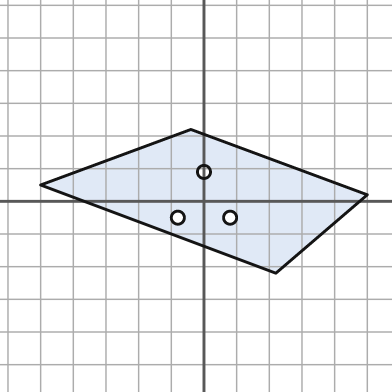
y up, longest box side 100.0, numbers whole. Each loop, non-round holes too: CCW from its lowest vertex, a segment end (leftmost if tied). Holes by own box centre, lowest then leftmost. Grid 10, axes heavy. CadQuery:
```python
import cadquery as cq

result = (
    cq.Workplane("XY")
    .moveTo(22.0, -22.0)
    .lineTo(50.0, 2.0)
    .lineTo(-4.0, 22.0)
    .lineTo(-50.0, 5.0)
    .close()
    .moveTo(-8.0, -5.0)
    .circle(2.0)
    .moveTo(8.0, -5.0)
    .circle(2.0)
    .moveTo(0.0, 9.0)
    .circle(2.0)
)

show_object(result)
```